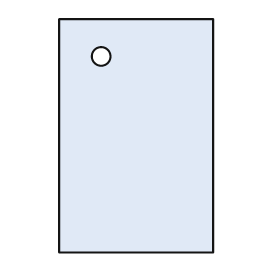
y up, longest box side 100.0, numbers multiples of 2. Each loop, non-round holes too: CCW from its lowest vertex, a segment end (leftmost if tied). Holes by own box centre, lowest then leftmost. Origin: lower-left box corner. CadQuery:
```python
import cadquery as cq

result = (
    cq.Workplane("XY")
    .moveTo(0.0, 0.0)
    .lineTo(66.0, 0.0)
    .lineTo(66.0, 100.0)
    .lineTo(0.0, 100.0)
    .close()
    .moveTo(18.0, 84.0)
    .circle(4.0)
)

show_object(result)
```